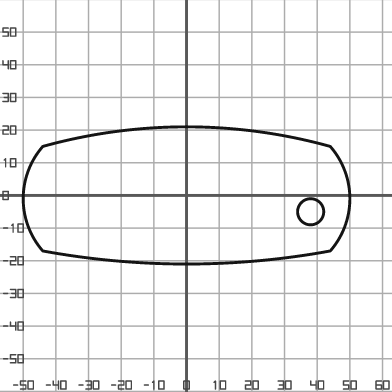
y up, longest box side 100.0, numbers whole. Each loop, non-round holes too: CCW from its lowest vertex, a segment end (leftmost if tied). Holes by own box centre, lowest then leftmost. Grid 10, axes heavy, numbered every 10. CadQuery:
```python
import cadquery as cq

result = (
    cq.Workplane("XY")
    .moveTo(-44.0, -17.0)
    .threePointArc((0.0, -21.0), (44.0, -17.0))
    .threePointArc((50.0, -1.0), (44.0, 15.0))
    .threePointArc((0.0, 21.0), (-44.0, 15.0))
    .threePointArc((-50.0, -1.0), (-44.0, -17.0))
    .close()
    .moveTo(38.0, -5.0)
    .circle(4.0)
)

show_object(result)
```